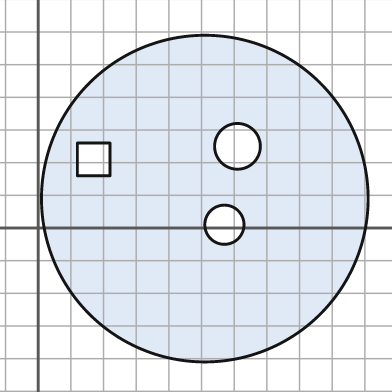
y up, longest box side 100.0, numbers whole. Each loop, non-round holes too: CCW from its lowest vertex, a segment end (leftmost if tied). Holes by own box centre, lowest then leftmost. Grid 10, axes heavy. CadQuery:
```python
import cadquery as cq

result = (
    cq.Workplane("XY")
    .moveTo(51.0, 9.0)
    .circle(50.0)
    .moveTo(57.0, 1.0)
    .circle(6.0)
    .moveTo(12.0, 16.0)
    .lineTo(22.0, 16.0)
    .lineTo(22.0, 26.0)
    .lineTo(12.0, 26.0)
    .close()
    .moveTo(61.0, 25.0)
    .circle(7.0)
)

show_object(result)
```